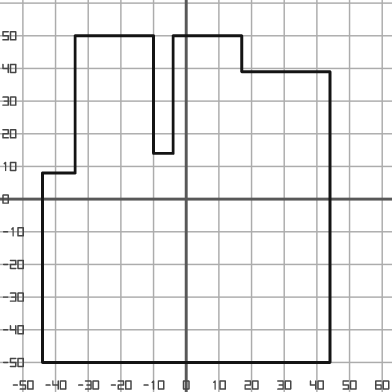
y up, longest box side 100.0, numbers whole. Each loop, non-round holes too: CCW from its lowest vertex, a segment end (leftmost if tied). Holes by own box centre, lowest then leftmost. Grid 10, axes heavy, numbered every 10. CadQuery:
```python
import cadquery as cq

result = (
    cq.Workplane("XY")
    .moveTo(-44.0, -50.0)
    .lineTo(44.0, -50.0)
    .lineTo(44.0, 39.0)
    .lineTo(17.0, 39.0)
    .lineTo(17.0, 50.0)
    .lineTo(-4.0, 50.0)
    .lineTo(-4.0, 14.0)
    .lineTo(-10.0, 14.0)
    .lineTo(-10.0, 50.0)
    .lineTo(-34.0, 50.0)
    .lineTo(-34.0, 8.0)
    .lineTo(-44.0, 8.0)
    .close()
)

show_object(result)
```